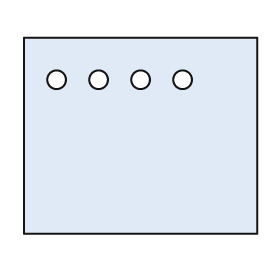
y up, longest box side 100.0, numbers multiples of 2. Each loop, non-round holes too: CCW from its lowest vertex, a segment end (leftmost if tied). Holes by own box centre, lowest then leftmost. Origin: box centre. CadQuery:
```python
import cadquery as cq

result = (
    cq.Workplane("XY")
    .moveTo(-50.0, -42.0)
    .lineTo(50.0, -42.0)
    .lineTo(50.0, 42.0)
    .lineTo(-50.0, 42.0)
    .close()
    .moveTo(-36.0, 24.0)
    .circle(4.0)
    .moveTo(-18.0, 24.0)
    .circle(4.0)
    .moveTo(0.0, 24.0)
    .circle(4.0)
    .moveTo(18.0, 24.0)
    .circle(4.0)
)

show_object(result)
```